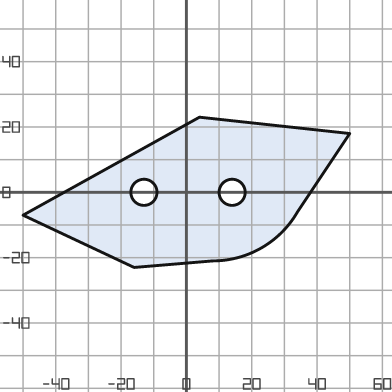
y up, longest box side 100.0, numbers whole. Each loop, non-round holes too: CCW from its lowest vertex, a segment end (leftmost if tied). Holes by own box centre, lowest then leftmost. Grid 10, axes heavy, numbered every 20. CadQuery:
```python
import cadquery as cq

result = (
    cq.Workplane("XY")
    .moveTo(-16.0, -23.0)
    .lineTo(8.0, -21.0)
    .threePointArc((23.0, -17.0), (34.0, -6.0))
    .lineTo(50.0, 18.0)
    .lineTo(4.0, 23.0)
    .lineTo(-50.0, -7.0)
    .close()
    .moveTo(-13.0, 0.0)
    .circle(4.0)
    .moveTo(14.0, 0.0)
    .circle(4.0)
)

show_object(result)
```